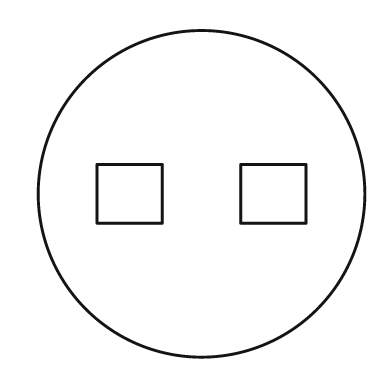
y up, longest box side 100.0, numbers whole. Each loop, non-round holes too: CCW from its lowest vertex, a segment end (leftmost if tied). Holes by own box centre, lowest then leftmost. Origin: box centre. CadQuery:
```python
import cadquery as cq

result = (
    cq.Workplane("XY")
    .moveTo(0.0, 0.0)
    .circle(50.0)
    .moveTo(-32.0, -9.0)
    .lineTo(-12.0, -9.0)
    .lineTo(-12.0, 9.0)
    .lineTo(-32.0, 9.0)
    .close()
    .moveTo(12.0, -9.0)
    .lineTo(32.0, -9.0)
    .lineTo(32.0, 9.0)
    .lineTo(12.0, 9.0)
    .close()
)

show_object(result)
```